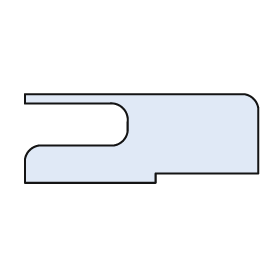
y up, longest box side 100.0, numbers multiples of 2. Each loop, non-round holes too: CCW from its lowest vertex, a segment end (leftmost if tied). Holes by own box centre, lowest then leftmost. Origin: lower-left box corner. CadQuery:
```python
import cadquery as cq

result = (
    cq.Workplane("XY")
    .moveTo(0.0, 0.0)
    .lineTo(56.0, 0.0)
    .lineTo(56.0, 4.0)
    .lineTo(100.0, 4.0)
    .lineTo(100.0, 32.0)
    .threePointArc((98.0, 36.0), (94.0, 38.0))
    .lineTo(0.0, 38.0)
    .lineTo(0.0, 34.0)
    .lineTo(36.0, 34.0)
    .threePointArc((42.0, 32.0), (44.0, 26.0))
    .lineTo(44.0, 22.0)
    .threePointArc((42.0, 18.0), (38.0, 16.0))
    .lineTo(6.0, 16.0)
    .threePointArc((2.0, 14.0), (0.0, 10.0))
    .close()
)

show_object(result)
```